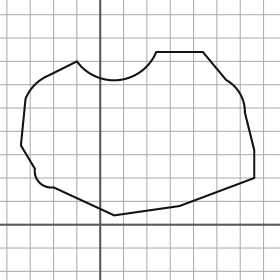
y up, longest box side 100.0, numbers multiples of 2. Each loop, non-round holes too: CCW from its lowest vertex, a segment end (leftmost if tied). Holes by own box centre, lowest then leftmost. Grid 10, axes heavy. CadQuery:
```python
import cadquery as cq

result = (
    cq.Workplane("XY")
    .moveTo(6.0, 4.0)
    .lineTo(34.0, 8.0)
    .lineTo(66.0, 20.0)
    .lineTo(66.0, 32.0)
    .lineTo(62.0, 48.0)
    .threePointArc((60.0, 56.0), (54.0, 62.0))
    .lineTo(44.0, 74.0)
    .lineTo(24.0, 74.0)
    .threePointArc((8.0, 62.0), (-10.0, 70.0))
    .lineTo(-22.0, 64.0)
    .threePointArc((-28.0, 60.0), (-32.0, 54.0))
    .lineTo(-34.0, 34.0)
    .lineTo(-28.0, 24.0)
    .threePointArc((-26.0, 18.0), (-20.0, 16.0))
    .close()
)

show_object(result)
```